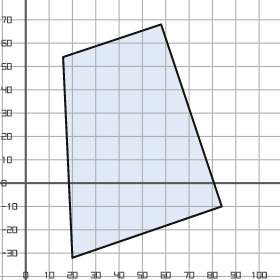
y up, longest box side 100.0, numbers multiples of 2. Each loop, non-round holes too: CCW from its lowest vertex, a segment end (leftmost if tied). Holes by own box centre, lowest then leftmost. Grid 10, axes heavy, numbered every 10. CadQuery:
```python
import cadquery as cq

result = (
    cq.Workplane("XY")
    .moveTo(20.0, -32.0)
    .lineTo(84.0, -10.0)
    .lineTo(58.0, 68.0)
    .lineTo(16.0, 54.0)
    .close()
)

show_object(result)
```